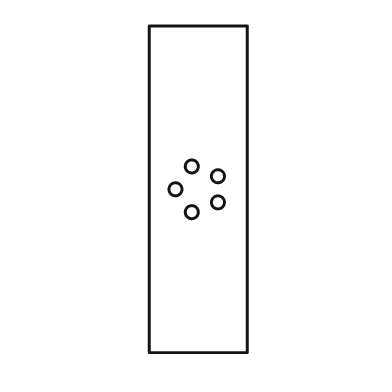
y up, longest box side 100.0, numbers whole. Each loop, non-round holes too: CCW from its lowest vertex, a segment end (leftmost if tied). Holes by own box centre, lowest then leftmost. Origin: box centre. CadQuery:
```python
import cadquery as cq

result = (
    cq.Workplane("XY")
    .moveTo(-15.0, -50.0)
    .lineTo(15.0, -50.0)
    .lineTo(15.0, 50.0)
    .lineTo(-15.0, 50.0)
    .close()
    .moveTo(-2.0, -7.0)
    .circle(2.0)
    .moveTo(6.0, -4.0)
    .circle(2.0)
    .moveTo(-7.0, 0.0)
    .circle(2.0)
    .moveTo(6.0, 4.0)
    .circle(2.0)
    .moveTo(-2.0, 7.0)
    .circle(2.0)
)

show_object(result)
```